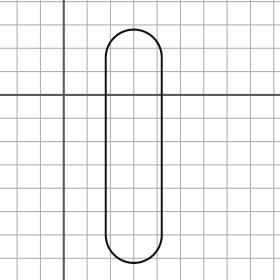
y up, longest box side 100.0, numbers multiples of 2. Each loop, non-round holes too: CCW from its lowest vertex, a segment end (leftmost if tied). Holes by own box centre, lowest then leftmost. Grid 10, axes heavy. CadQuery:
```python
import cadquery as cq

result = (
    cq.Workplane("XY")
    .moveTo(18.0, -60.0)
    .threePointArc((30.0, -72.0), (42.0, -60.0))
    .lineTo(42.0, 16.0)
    .threePointArc((30.0, 28.0), (18.0, 16.0))
    .close()
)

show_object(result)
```